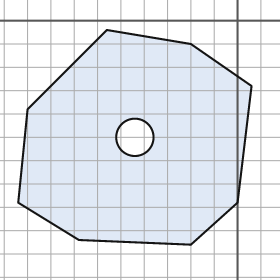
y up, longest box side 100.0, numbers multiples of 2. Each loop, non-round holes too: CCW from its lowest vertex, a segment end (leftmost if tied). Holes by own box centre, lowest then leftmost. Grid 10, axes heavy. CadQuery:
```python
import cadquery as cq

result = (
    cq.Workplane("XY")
    .moveTo(-20.0, -96.0)
    .lineTo(0.0, -78.0)
    .lineTo(6.0, -28.0)
    .lineTo(-20.0, -10.0)
    .lineTo(-56.0, -4.0)
    .lineTo(-90.0, -38.0)
    .lineTo(-94.0, -78.0)
    .lineTo(-68.0, -94.0)
    .close()
    .moveTo(-44.0, -50.0)
    .circle(8.0)
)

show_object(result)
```